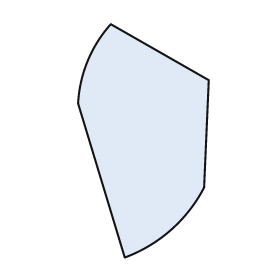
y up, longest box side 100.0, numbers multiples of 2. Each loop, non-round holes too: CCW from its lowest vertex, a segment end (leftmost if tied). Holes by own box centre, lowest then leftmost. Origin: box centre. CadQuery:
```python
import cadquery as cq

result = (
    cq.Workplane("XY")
    .moveTo(-8.0, -50.0)
    .threePointArc((12.0, -38.0), (26.0, -20.0))
    .lineTo(28.0, 26.0)
    .lineTo(-14.0, 50.0)
    .threePointArc((-24.0, 34.0), (-28.0, 16.0))
    .close()
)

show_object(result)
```